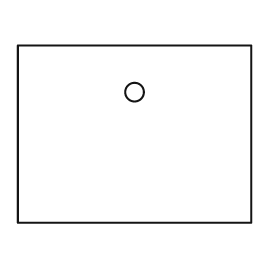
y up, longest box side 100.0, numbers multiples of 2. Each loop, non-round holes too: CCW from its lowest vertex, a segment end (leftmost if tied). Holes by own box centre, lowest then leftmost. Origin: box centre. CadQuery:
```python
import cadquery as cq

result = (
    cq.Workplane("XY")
    .moveTo(-50.0, -38.0)
    .lineTo(50.0, -38.0)
    .lineTo(50.0, 38.0)
    .lineTo(-50.0, 38.0)
    .close()
    .moveTo(0.0, 18.0)
    .circle(4.0)
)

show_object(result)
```